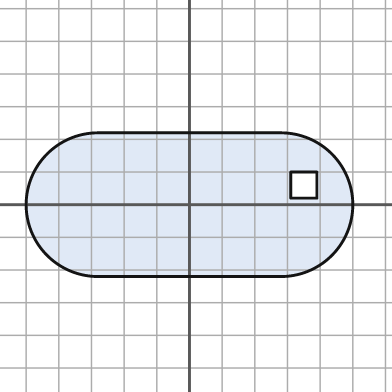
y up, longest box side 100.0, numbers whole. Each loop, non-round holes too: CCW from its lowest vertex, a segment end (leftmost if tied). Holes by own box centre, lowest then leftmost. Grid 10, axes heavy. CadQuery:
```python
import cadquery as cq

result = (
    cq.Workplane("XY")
    .moveTo(-28.0, -22.0)
    .lineTo(28.0, -22.0)
    .threePointArc((50.0, 0.0), (28.0, 22.0))
    .lineTo(-28.0, 22.0)
    .threePointArc((-50.0, 0.0), (-28.0, -22.0))
    .close()
    .moveTo(31.0, 2.0)
    .lineTo(39.0, 2.0)
    .lineTo(39.0, 10.0)
    .lineTo(31.0, 10.0)
    .close()
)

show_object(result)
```